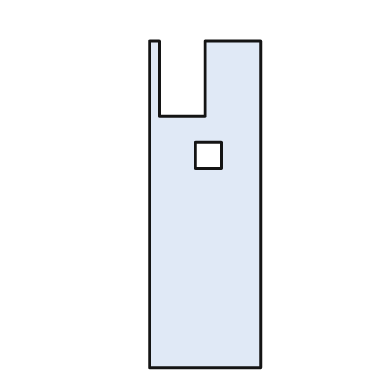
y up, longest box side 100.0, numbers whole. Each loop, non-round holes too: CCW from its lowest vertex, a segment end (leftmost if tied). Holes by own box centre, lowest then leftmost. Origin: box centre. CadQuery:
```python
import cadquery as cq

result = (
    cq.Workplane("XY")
    .moveTo(-17.0, -50.0)
    .lineTo(17.0, -50.0)
    .lineTo(17.0, 50.0)
    .lineTo(0.0, 50.0)
    .lineTo(0.0, 27.0)
    .lineTo(-14.0, 27.0)
    .lineTo(-14.0, 50.0)
    .lineTo(-17.0, 50.0)
    .close()
    .moveTo(-3.0, 11.0)
    .lineTo(5.0, 11.0)
    .lineTo(5.0, 19.0)
    .lineTo(-3.0, 19.0)
    .close()
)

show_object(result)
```